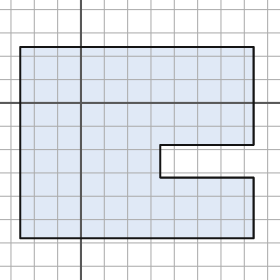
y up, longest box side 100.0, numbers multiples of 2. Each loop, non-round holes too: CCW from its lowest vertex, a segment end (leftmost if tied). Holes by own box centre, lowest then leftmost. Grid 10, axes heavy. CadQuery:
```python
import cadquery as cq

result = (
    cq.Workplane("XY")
    .moveTo(-26.0, -58.0)
    .lineTo(74.0, -58.0)
    .lineTo(74.0, -32.0)
    .lineTo(34.0, -32.0)
    .lineTo(34.0, -18.0)
    .lineTo(74.0, -18.0)
    .lineTo(74.0, 24.0)
    .lineTo(-26.0, 24.0)
    .close()
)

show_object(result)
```